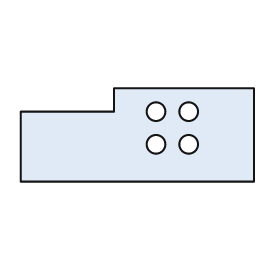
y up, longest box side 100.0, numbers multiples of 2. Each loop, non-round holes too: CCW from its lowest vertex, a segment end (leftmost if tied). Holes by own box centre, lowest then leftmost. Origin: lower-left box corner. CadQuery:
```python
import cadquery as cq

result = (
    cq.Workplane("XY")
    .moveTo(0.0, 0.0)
    .lineTo(100.0, 0.0)
    .lineTo(100.0, 40.0)
    .lineTo(40.0, 40.0)
    .lineTo(40.0, 30.0)
    .lineTo(0.0, 30.0)
    .close()
    .moveTo(58.0, 16.0)
    .circle(4.0)
    .moveTo(72.0, 16.0)
    .circle(4.0)
    .moveTo(58.0, 30.0)
    .circle(4.0)
    .moveTo(72.0, 30.0)
    .circle(4.0)
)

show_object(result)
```